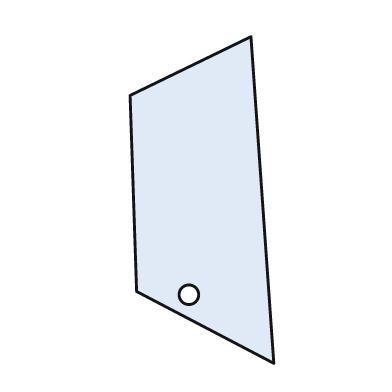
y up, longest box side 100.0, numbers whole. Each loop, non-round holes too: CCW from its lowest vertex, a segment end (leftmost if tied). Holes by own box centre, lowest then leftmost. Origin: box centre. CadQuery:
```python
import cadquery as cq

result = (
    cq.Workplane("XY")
    .moveTo(22.0, -50.0)
    .lineTo(15.0, 50.0)
    .lineTo(-22.0, 32.0)
    .lineTo(-20.0, -28.0)
    .close()
    .moveTo(-4.0, -29.0)
    .circle(3.0)
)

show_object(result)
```